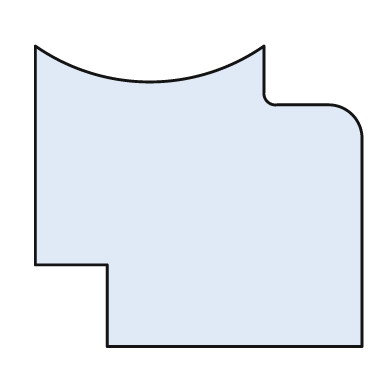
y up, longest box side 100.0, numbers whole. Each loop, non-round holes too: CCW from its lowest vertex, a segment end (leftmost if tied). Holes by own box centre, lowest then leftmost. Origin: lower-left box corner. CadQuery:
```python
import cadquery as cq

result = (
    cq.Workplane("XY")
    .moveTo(22.0, 0.0)
    .lineTo(100.0, 0.0)
    .lineTo(100.0, 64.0)
    .threePointArc((97.0, 71.0), (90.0, 74.0))
    .lineTo(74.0, 74.0)
    .threePointArc((71.0, 75.0), (70.0, 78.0))
    .lineTo(70.0, 92.0)
    .threePointArc((35.0, 81.0), (0.0, 92.0))
    .lineTo(0.0, 25.0)
    .lineTo(22.0, 25.0)
    .close()
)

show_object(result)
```